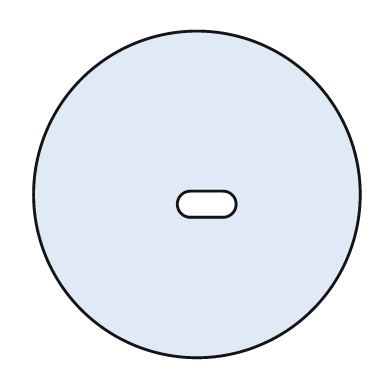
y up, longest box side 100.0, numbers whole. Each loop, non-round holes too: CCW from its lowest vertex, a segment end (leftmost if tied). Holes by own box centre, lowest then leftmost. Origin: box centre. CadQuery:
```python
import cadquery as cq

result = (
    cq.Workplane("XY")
    .moveTo(0.0, 0.0)
    .circle(50.0)
    .moveTo(-2.0, -7.0)
    .lineTo(8.0, -7.0)
    .threePointArc((12.0, -3.0), (8.0, 1.0))
    .lineTo(-2.0, 1.0)
    .threePointArc((-6.0, -3.0), (-2.0, -7.0))
    .close()
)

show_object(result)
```